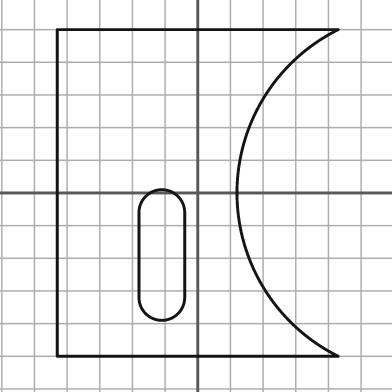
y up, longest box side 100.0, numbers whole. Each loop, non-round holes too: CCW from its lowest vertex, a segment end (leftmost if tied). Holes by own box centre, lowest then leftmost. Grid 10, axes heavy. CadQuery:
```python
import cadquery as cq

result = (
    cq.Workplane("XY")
    .moveTo(-43.0, -50.0)
    .lineTo(43.0, -50.0)
    .threePointArc((12.0, 0.0), (43.0, 50.0))
    .lineTo(-43.0, 50.0)
    .close()
    .moveTo(-18.0, -32.0)
    .threePointArc((-11.0, -39.0), (-4.0, -32.0))
    .lineTo(-4.0, -6.0)
    .threePointArc((-11.0, 1.0), (-18.0, -6.0))
    .close()
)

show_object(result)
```